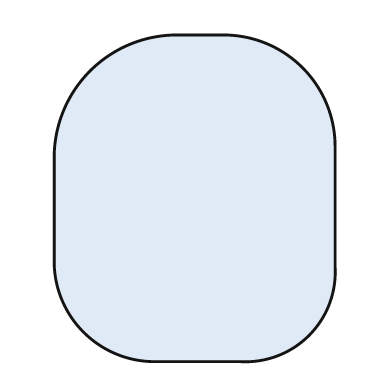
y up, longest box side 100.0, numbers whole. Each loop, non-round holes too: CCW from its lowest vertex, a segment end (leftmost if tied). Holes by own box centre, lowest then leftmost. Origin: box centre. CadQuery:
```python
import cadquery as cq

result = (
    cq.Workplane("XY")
    .moveTo(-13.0, -50.0)
    .lineTo(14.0, -50.0)
    .threePointArc((35.0, -42.0), (43.0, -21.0))
    .lineTo(43.0, 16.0)
    .threePointArc((33.0, 40.0), (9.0, 50.0))
    .lineTo(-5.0, 50.0)
    .threePointArc((-32.0, 39.0), (-43.0, 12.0))
    .lineTo(-43.0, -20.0)
    .threePointArc((-34.0, -41.0), (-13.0, -50.0))
    .close()
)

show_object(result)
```